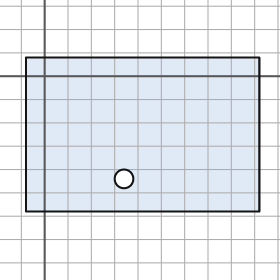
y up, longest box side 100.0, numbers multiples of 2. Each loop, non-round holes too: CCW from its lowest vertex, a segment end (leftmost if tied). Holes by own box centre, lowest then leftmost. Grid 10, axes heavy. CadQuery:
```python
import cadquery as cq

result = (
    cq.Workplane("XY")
    .moveTo(-8.0, -58.0)
    .lineTo(92.0, -58.0)
    .lineTo(92.0, 8.0)
    .lineTo(-8.0, 8.0)
    .close()
    .moveTo(34.0, -44.0)
    .circle(4.0)
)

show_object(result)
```